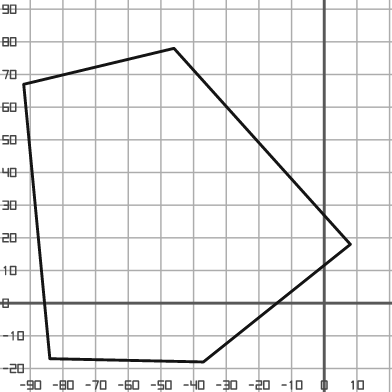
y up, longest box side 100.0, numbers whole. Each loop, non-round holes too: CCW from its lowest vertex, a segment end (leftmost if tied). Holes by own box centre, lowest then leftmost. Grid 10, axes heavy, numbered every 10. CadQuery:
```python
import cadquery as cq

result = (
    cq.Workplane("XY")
    .moveTo(-37.0, -18.0)
    .lineTo(8.0, 18.0)
    .lineTo(-46.0, 78.0)
    .lineTo(-92.0, 67.0)
    .lineTo(-84.0, -17.0)
    .close()
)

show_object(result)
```